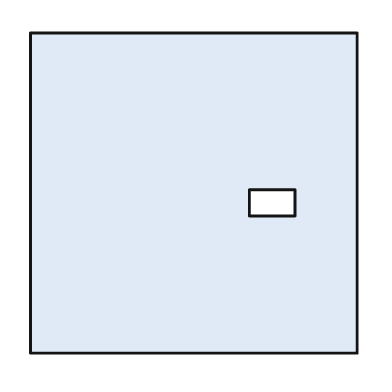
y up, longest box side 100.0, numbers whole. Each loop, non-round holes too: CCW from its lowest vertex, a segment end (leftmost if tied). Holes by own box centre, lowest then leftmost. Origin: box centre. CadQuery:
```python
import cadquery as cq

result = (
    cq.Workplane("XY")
    .moveTo(-50.0, -49.0)
    .lineTo(50.0, -49.0)
    .lineTo(50.0, 49.0)
    .lineTo(-50.0, 49.0)
    .close()
    .moveTo(17.0, -7.0)
    .lineTo(31.0, -7.0)
    .lineTo(31.0, 1.0)
    .lineTo(17.0, 1.0)
    .close()
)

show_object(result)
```